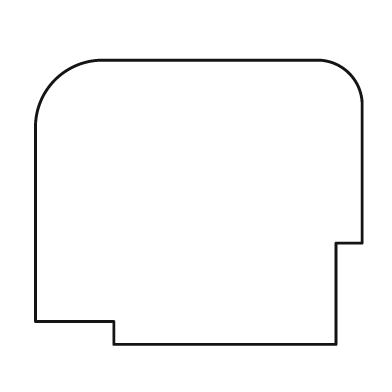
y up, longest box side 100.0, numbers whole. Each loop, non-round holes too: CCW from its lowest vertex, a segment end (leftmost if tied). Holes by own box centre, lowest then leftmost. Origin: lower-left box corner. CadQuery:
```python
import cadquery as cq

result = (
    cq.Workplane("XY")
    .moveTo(24.0, 0.0)
    .lineTo(92.0, 0.0)
    .lineTo(92.0, 31.0)
    .lineTo(100.0, 31.0)
    .lineTo(100.0, 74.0)
    .threePointArc((96.0, 83.0), (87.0, 87.0))
    .lineTo(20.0, 87.0)
    .threePointArc((6.0, 81.0), (0.0, 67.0))
    .lineTo(0.0, 7.0)
    .lineTo(24.0, 7.0)
    .close()
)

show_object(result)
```